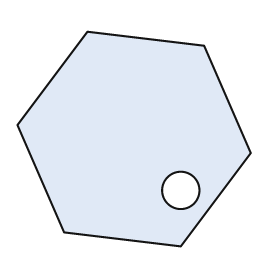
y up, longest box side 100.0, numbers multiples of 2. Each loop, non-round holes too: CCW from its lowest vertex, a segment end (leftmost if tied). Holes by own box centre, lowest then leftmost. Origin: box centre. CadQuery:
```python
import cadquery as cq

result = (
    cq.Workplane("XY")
    .moveTo(20.0, -46.0)
    .lineTo(50.0, -6.0)
    .lineTo(30.0, 40.0)
    .lineTo(-20.0, 46.0)
    .lineTo(-50.0, 6.0)
    .lineTo(-30.0, -40.0)
    .close()
    .moveTo(20.0, -22.0)
    .circle(8.0)
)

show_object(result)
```